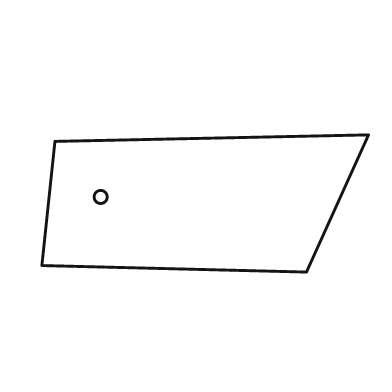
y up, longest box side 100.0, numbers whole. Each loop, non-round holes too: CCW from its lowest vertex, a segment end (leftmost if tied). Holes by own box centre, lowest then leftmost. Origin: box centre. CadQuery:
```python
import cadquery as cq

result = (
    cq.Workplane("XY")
    .moveTo(31.0, -21.0)
    .lineTo(50.0, 21.0)
    .lineTo(-46.0, 19.0)
    .lineTo(-50.0, -19.0)
    .close()
    .moveTo(-32.0, 2.0)
    .circle(2.0)
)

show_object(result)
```